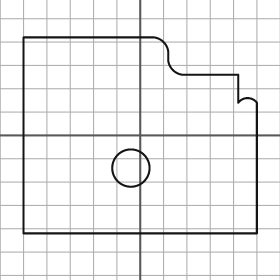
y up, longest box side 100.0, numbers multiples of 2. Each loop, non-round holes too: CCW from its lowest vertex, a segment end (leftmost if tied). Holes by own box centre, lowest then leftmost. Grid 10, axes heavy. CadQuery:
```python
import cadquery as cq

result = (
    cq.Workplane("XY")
    .moveTo(-50.0, -42.0)
    .lineTo(50.0, -42.0)
    .lineTo(50.0, 14.0)
    .threePointArc((46.0, 16.0), (42.0, 14.0))
    .lineTo(42.0, 26.0)
    .lineTo(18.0, 26.0)
    .threePointArc((14.0, 28.0), (12.0, 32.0))
    .lineTo(12.0, 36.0)
    .threePointArc((10.0, 40.0), (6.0, 42.0))
    .lineTo(-50.0, 42.0)
    .close()
    .moveTo(-4.0, -14.0)
    .circle(8.0)
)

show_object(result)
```